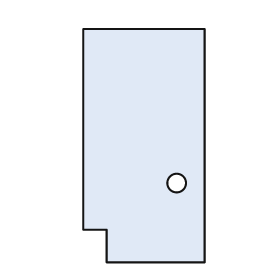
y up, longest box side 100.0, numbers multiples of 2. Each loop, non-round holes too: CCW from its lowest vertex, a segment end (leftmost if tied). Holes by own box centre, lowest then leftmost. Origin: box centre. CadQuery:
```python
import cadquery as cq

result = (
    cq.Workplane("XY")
    .moveTo(-16.0, -50.0)
    .lineTo(26.0, -50.0)
    .lineTo(26.0, 50.0)
    .lineTo(-26.0, 50.0)
    .lineTo(-26.0, -36.0)
    .lineTo(-16.0, -36.0)
    .close()
    .moveTo(14.0, -16.0)
    .circle(4.0)
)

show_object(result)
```